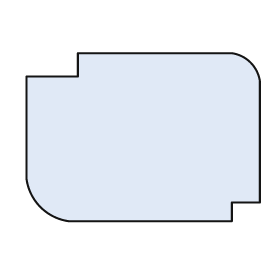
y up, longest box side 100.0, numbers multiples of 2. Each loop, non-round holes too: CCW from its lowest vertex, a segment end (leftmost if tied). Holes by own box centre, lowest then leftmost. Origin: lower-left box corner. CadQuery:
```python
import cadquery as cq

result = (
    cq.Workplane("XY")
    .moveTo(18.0, 0.0)
    .lineTo(88.0, 0.0)
    .lineTo(88.0, 8.0)
    .lineTo(100.0, 8.0)
    .lineTo(100.0, 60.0)
    .threePointArc((96.0, 68.0), (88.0, 72.0))
    .lineTo(22.0, 72.0)
    .lineTo(22.0, 62.0)
    .lineTo(0.0, 62.0)
    .lineTo(0.0, 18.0)
    .threePointArc((6.0, 6.0), (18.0, 0.0))
    .close()
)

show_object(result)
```